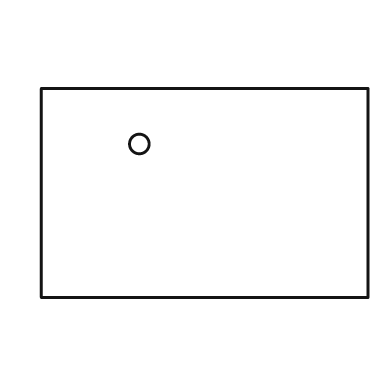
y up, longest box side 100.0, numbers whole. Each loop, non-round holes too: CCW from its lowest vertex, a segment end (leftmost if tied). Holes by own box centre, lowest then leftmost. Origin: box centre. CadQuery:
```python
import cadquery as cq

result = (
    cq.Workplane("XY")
    .moveTo(-50.0, -32.0)
    .lineTo(50.0, -32.0)
    .lineTo(50.0, 32.0)
    .lineTo(-50.0, 32.0)
    .close()
    .moveTo(-20.0, 15.0)
    .circle(3.0)
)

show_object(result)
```